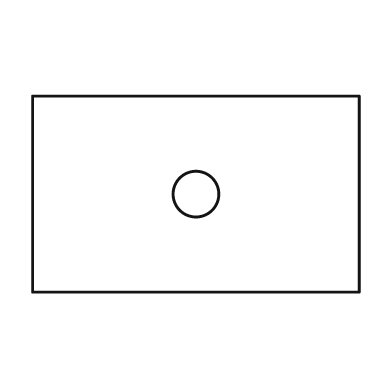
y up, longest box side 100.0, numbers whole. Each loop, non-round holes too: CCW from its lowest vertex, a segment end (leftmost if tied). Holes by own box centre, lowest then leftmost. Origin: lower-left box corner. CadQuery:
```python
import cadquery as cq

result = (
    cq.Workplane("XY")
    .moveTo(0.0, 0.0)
    .lineTo(100.0, 0.0)
    .lineTo(100.0, 60.0)
    .lineTo(0.0, 60.0)
    .close()
    .moveTo(50.0, 30.0)
    .circle(7.0)
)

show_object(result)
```